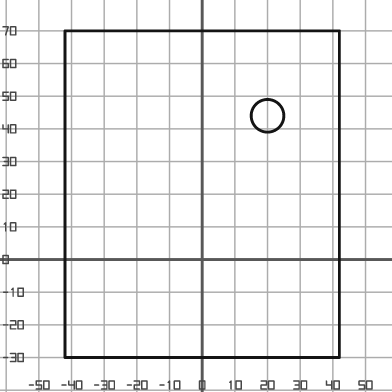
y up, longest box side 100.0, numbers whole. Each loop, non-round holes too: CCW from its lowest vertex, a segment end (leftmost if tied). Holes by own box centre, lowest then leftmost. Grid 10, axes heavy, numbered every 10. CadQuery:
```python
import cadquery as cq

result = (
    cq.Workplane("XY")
    .moveTo(-42.0, -30.0)
    .lineTo(42.0, -30.0)
    .lineTo(42.0, 70.0)
    .lineTo(-42.0, 70.0)
    .close()
    .moveTo(20.0, 44.0)
    .circle(5.0)
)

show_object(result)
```